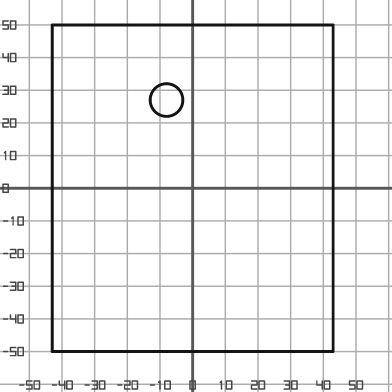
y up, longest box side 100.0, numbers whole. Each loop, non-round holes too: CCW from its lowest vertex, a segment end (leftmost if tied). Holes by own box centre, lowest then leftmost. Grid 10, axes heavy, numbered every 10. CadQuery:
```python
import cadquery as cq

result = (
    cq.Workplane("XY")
    .moveTo(-43.0, -50.0)
    .lineTo(43.0, -50.0)
    .lineTo(43.0, 50.0)
    .lineTo(-43.0, 50.0)
    .close()
    .moveTo(-8.0, 27.0)
    .circle(5.0)
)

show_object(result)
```